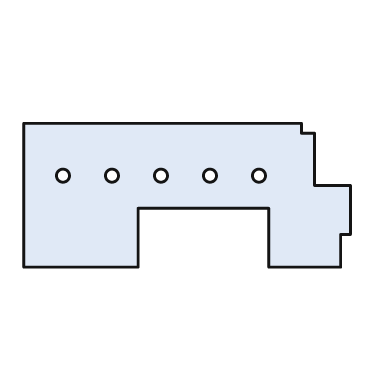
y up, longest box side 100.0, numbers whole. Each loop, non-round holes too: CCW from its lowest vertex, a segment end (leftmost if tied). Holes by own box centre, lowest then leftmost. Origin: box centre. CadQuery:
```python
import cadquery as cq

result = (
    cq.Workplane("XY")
    .moveTo(-50.0, -22.0)
    .lineTo(-15.0, -22.0)
    .lineTo(-15.0, -4.0)
    .lineTo(25.0, -4.0)
    .lineTo(25.0, -22.0)
    .lineTo(47.0, -22.0)
    .lineTo(47.0, -12.0)
    .lineTo(50.0, -12.0)
    .lineTo(50.0, 3.0)
    .lineTo(39.0, 3.0)
    .lineTo(39.0, 19.0)
    .lineTo(35.0, 19.0)
    .lineTo(35.0, 22.0)
    .lineTo(-50.0, 22.0)
    .close()
    .moveTo(-38.0, 6.0)
    .circle(2.0)
    .moveTo(-23.0, 6.0)
    .circle(2.0)
    .moveTo(-8.0, 6.0)
    .circle(2.0)
    .moveTo(7.0, 6.0)
    .circle(2.0)
    .moveTo(22.0, 6.0)
    .circle(2.0)
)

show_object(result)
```